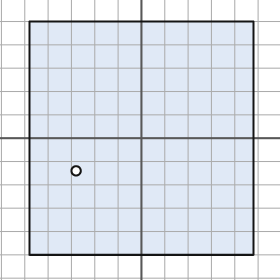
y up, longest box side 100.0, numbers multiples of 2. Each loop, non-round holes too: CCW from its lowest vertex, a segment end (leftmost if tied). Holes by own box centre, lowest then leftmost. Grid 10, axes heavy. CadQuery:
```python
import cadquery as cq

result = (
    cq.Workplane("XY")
    .moveTo(-48.0, -50.0)
    .lineTo(48.0, -50.0)
    .lineTo(48.0, 50.0)
    .lineTo(-48.0, 50.0)
    .close()
    .moveTo(-28.0, -14.0)
    .circle(2.0)
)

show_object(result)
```